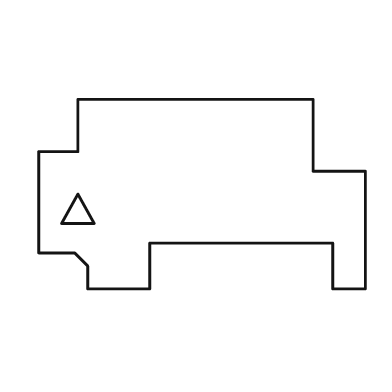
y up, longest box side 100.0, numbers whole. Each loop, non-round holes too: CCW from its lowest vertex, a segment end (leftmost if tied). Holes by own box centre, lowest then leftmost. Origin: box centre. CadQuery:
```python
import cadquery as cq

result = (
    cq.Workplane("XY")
    .moveTo(-35.0, -29.0)
    .lineTo(-16.0, -29.0)
    .lineTo(-16.0, -15.0)
    .lineTo(40.0, -15.0)
    .lineTo(40.0, -29.0)
    .lineTo(50.0, -29.0)
    .lineTo(50.0, 7.0)
    .lineTo(34.0, 7.0)
    .lineTo(34.0, 29.0)
    .lineTo(-38.0, 29.0)
    .lineTo(-38.0, 13.0)
    .lineTo(-50.0, 13.0)
    .lineTo(-50.0, -18.0)
    .lineTo(-39.0, -18.0)
    .lineTo(-35.0, -22.0)
    .close()
    .moveTo(-43.0, -9.0)
    .lineTo(-33.0, -9.0)
    .lineTo(-38.0, 0.0)
    .close()
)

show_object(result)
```